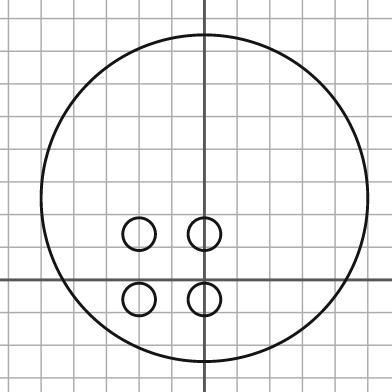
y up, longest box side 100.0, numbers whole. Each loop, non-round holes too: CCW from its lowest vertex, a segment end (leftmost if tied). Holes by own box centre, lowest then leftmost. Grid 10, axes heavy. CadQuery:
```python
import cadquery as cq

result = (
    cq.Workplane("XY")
    .moveTo(0.0, 25.0)
    .circle(50.0)
    .moveTo(-20.0, -6.0)
    .circle(5.0)
    .moveTo(0.0, -6.0)
    .circle(5.0)
    .moveTo(-20.0, 14.0)
    .circle(5.0)
    .moveTo(0.0, 14.0)
    .circle(5.0)
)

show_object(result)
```